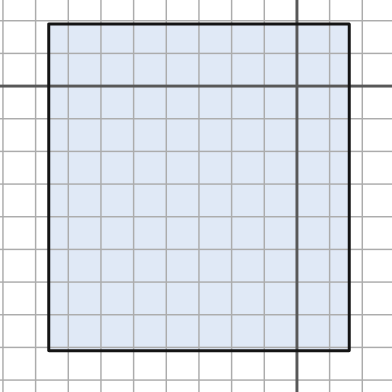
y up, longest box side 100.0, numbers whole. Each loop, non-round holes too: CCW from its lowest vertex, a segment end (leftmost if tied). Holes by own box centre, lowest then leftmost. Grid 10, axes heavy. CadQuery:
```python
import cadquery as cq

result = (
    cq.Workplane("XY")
    .moveTo(-76.0, -81.0)
    .lineTo(16.0, -81.0)
    .lineTo(16.0, 19.0)
    .lineTo(-76.0, 19.0)
    .close()
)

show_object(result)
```